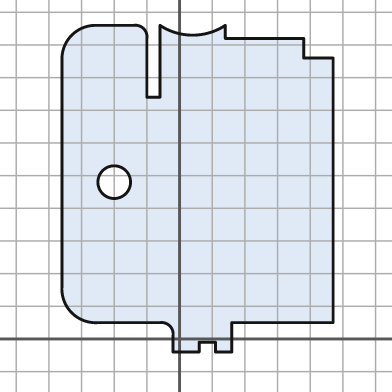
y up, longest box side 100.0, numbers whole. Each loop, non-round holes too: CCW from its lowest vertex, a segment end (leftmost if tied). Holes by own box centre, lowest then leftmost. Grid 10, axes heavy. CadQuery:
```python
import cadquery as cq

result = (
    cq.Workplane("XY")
    .moveTo(-2.0, -4.0)
    .lineTo(6.0, -4.0)
    .lineTo(6.0, -1.0)
    .lineTo(11.0, -1.0)
    .lineTo(11.0, -4.0)
    .lineTo(16.0, -4.0)
    .lineTo(16.0, 5.0)
    .lineTo(47.0, 5.0)
    .lineTo(47.0, 86.0)
    .lineTo(38.0, 86.0)
    .lineTo(38.0, 92.0)
    .lineTo(14.0, 92.0)
    .lineTo(14.0, 96.0)
    .threePointArc((4.0, 93.0), (-6.0, 96.0))
    .lineTo(-6.0, 74.0)
    .lineTo(-10.0, 74.0)
    .lineTo(-10.0, 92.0)
    .threePointArc((-11.0, 95.0), (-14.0, 96.0))
    .lineTo(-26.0, 96.0)
    .threePointArc((-33.0, 93.0), (-36.0, 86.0))
    .lineTo(-36.0, 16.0)
    .threePointArc((-33.0, 8.0), (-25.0, 5.0))
    .lineTo(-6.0, 5.0)
    .threePointArc((-3.0, 4.0), (-2.0, 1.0))
    .close()
    .moveTo(-20.0, 48.0)
    .circle(5.0)
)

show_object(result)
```